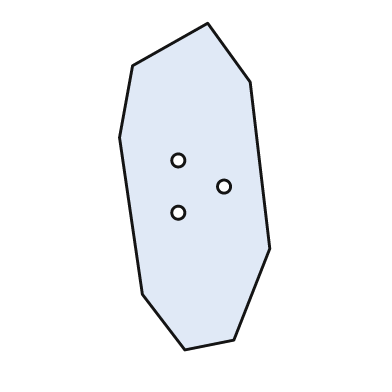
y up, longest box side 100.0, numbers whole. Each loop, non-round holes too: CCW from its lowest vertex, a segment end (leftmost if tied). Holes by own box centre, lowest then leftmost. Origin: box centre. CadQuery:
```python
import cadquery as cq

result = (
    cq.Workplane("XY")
    .moveTo(-3.0, -50.0)
    .lineTo(12.0, -47.0)
    .lineTo(23.0, -19.0)
    .lineTo(17.0, 32.0)
    .lineTo(4.0, 50.0)
    .lineTo(-19.0, 37.0)
    .lineTo(-23.0, 15.0)
    .lineTo(-16.0, -33.0)
    .close()
    .moveTo(-5.0, -8.0)
    .circle(2.0)
    .moveTo(9.0, 0.0)
    .circle(2.0)
    .moveTo(-5.0, 8.0)
    .circle(2.0)
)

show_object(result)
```